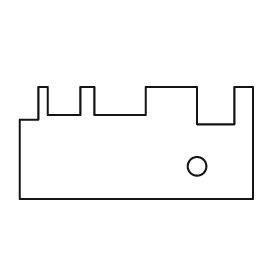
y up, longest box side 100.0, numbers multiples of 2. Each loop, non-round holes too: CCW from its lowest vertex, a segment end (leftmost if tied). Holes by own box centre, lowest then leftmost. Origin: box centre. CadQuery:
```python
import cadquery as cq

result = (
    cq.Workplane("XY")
    .moveTo(-50.0, -24.0)
    .lineTo(50.0, -24.0)
    .lineTo(50.0, 24.0)
    .lineTo(42.0, 24.0)
    .lineTo(42.0, 8.0)
    .lineTo(26.0, 8.0)
    .lineTo(26.0, 24.0)
    .lineTo(4.0, 24.0)
    .lineTo(4.0, 12.0)
    .lineTo(-18.0, 12.0)
    .lineTo(-18.0, 24.0)
    .lineTo(-24.0, 24.0)
    .lineTo(-24.0, 12.0)
    .lineTo(-38.0, 12.0)
    .lineTo(-38.0, 24.0)
    .lineTo(-42.0, 24.0)
    .lineTo(-42.0, 10.0)
    .lineTo(-50.0, 10.0)
    .close()
    .moveTo(26.0, -10.0)
    .circle(4.0)
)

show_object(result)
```